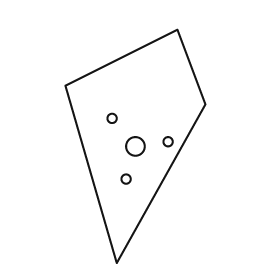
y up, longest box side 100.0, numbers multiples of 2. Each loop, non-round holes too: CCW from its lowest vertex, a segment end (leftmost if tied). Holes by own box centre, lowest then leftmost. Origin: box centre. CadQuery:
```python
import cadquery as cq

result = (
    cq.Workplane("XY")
    .moveTo(-8.0, -50.0)
    .lineTo(30.0, 18.0)
    .lineTo(18.0, 50.0)
    .lineTo(-30.0, 26.0)
    .close()
    .moveTo(-4.0, -14.0)
    .circle(2.0)
    .moveTo(0.0, 0.0)
    .circle(4.0)
    .moveTo(14.0, 2.0)
    .circle(2.0)
    .moveTo(-10.0, 12.0)
    .circle(2.0)
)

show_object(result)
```